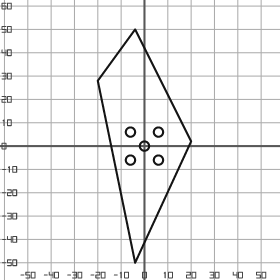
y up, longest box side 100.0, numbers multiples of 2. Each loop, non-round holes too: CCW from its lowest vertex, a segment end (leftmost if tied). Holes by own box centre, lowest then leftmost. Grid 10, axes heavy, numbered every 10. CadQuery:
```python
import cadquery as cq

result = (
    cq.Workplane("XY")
    .moveTo(-4.0, -50.0)
    .lineTo(20.0, 2.0)
    .lineTo(-4.0, 50.0)
    .lineTo(-20.0, 28.0)
    .close()
    .moveTo(-6.0, -6.0)
    .circle(2.0)
    .moveTo(6.0, -6.0)
    .circle(2.0)
    .moveTo(0.0, 0.0)
    .circle(2.0)
    .moveTo(-6.0, 6.0)
    .circle(2.0)
    .moveTo(6.0, 6.0)
    .circle(2.0)
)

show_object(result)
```